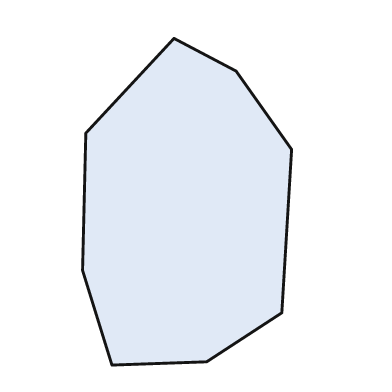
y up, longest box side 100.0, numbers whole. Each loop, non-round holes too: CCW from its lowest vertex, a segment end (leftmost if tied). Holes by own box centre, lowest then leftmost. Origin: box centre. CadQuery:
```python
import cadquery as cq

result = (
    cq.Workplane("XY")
    .moveTo(-23.0, -50.0)
    .lineTo(6.0, -49.0)
    .lineTo(29.0, -34.0)
    .lineTo(32.0, 16.0)
    .lineTo(15.0, 40.0)
    .lineTo(-4.0, 50.0)
    .lineTo(-31.0, 21.0)
    .lineTo(-32.0, -21.0)
    .close()
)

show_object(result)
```